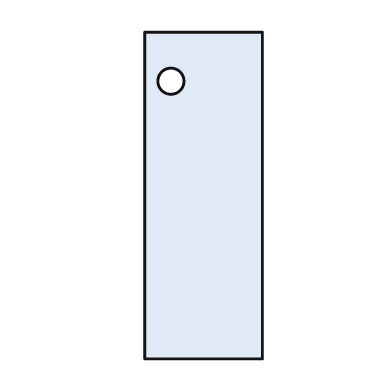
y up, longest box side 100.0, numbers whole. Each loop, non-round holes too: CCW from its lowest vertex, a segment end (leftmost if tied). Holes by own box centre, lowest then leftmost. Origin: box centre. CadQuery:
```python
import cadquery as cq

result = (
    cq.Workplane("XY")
    .moveTo(-18.0, -50.0)
    .lineTo(18.0, -50.0)
    .lineTo(18.0, 50.0)
    .lineTo(-18.0, 50.0)
    .close()
    .moveTo(-10.0, 35.0)
    .circle(4.0)
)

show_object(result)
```